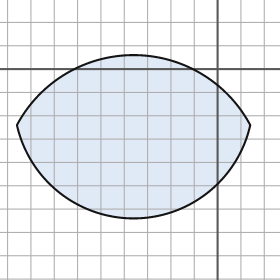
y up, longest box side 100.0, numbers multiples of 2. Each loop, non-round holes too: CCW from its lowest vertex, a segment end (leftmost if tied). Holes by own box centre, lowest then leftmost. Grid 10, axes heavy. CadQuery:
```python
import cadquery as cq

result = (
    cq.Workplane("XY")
    .moveTo(-86.0, -24.0)
    .threePointArc((-36.0, -64.0), (14.0, -24.0))
    .threePointArc((-36.0, 6.0), (-86.0, -24.0))
    .close()
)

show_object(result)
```